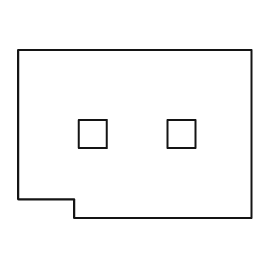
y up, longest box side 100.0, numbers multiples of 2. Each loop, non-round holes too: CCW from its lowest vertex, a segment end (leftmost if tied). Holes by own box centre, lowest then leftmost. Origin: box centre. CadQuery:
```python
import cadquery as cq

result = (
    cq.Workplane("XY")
    .moveTo(-26.0, -36.0)
    .lineTo(50.0, -36.0)
    .lineTo(50.0, 36.0)
    .lineTo(-50.0, 36.0)
    .lineTo(-50.0, -28.0)
    .lineTo(-26.0, -28.0)
    .close()
    .moveTo(-24.0, -6.0)
    .lineTo(-12.0, -6.0)
    .lineTo(-12.0, 6.0)
    .lineTo(-24.0, 6.0)
    .close()
    .moveTo(14.0, -6.0)
    .lineTo(26.0, -6.0)
    .lineTo(26.0, 6.0)
    .lineTo(14.0, 6.0)
    .close()
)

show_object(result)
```